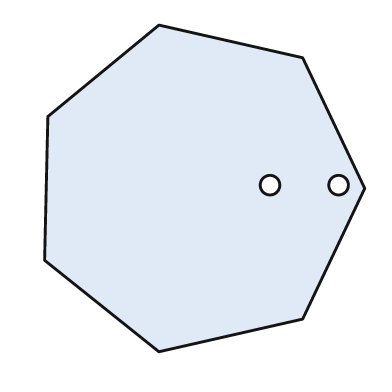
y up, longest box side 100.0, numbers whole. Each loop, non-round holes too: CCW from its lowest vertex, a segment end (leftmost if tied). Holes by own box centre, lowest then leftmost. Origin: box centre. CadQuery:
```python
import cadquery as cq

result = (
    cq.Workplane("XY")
    .moveTo(-14.0, -50.0)
    .lineTo(30.0, -40.0)
    .lineTo(49.0, 0.0)
    .lineTo(30.0, 40.0)
    .lineTo(-14.0, 50.0)
    .lineTo(-48.0, 22.0)
    .lineTo(-49.0, -22.0)
    .close()
    .moveTo(20.0, 1.0)
    .circle(3.0)
    .moveTo(41.0, 1.0)
    .circle(3.0)
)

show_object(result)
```